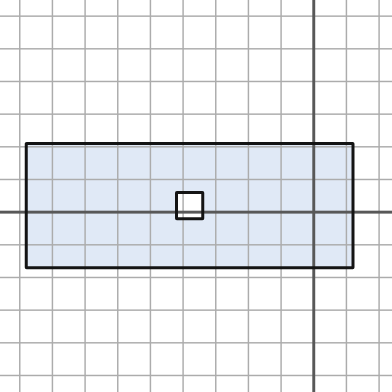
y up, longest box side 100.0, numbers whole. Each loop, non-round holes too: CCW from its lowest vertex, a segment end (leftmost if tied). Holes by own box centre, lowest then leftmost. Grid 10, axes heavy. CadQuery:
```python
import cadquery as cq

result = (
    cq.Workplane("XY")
    .moveTo(-88.0, -17.0)
    .lineTo(12.0, -17.0)
    .lineTo(12.0, 21.0)
    .lineTo(-88.0, 21.0)
    .close()
    .moveTo(-42.0, -2.0)
    .lineTo(-34.0, -2.0)
    .lineTo(-34.0, 6.0)
    .lineTo(-42.0, 6.0)
    .close()
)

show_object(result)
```